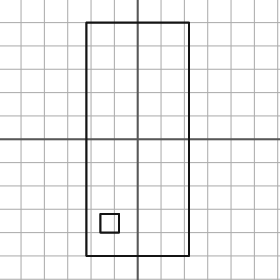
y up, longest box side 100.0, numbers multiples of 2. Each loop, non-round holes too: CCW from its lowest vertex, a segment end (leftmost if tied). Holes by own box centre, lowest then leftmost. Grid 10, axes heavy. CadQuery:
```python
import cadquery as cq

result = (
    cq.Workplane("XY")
    .moveTo(-22.0, -50.0)
    .lineTo(22.0, -50.0)
    .lineTo(22.0, 50.0)
    .lineTo(-22.0, 50.0)
    .close()
    .moveTo(-16.0, -40.0)
    .lineTo(-8.0, -40.0)
    .lineTo(-8.0, -32.0)
    .lineTo(-16.0, -32.0)
    .close()
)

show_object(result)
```